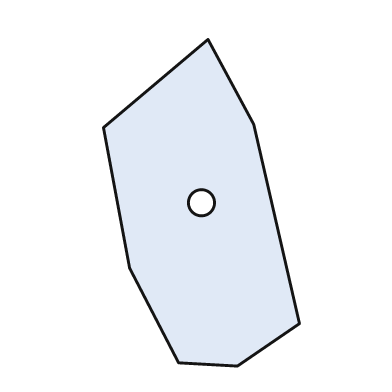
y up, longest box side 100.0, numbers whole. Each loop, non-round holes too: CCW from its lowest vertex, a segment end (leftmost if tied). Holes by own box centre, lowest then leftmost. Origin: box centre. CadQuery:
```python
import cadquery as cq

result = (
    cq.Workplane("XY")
    .moveTo(11.0, -50.0)
    .lineTo(30.0, -37.0)
    .lineTo(16.0, 24.0)
    .lineTo(2.0, 50.0)
    .lineTo(-30.0, 23.0)
    .lineTo(-22.0, -20.0)
    .lineTo(-7.0, -49.0)
    .close()
    .moveTo(0.0, 0.0)
    .circle(4.0)
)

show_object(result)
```